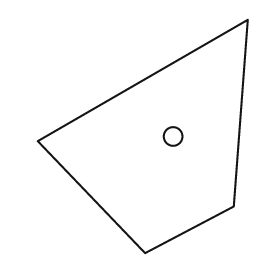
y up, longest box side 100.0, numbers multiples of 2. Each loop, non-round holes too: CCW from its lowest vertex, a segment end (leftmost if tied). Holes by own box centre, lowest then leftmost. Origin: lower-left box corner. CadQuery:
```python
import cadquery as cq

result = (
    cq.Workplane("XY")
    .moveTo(46.0, 0.0)
    .lineTo(84.0, 20.0)
    .lineTo(90.0, 100.0)
    .lineTo(0.0, 48.0)
    .close()
    .moveTo(58.0, 50.0)
    .circle(4.0)
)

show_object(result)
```